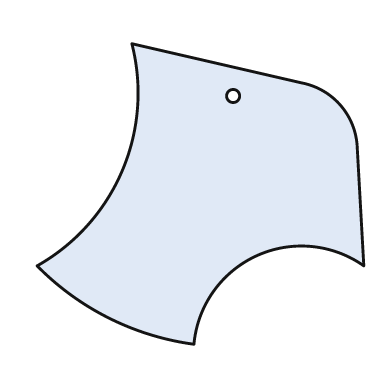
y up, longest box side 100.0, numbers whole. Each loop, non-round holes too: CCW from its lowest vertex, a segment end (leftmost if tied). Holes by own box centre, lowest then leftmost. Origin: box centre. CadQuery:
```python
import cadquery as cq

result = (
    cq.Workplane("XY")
    .moveTo(-2.0, -46.0)
    .threePointArc((17.0, -19.0), (50.0, -22.0))
    .lineTo(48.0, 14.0)
    .threePointArc((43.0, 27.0), (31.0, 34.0))
    .lineTo(-21.0, 46.0)
    .threePointArc((-24.0, 7.0), (-50.0, -22.0))
    .threePointArc((-28.0, -38.0), (-2.0, -46.0))
    .close()
    .moveTo(10.0, 30.0)
    .circle(2.0)
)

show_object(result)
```